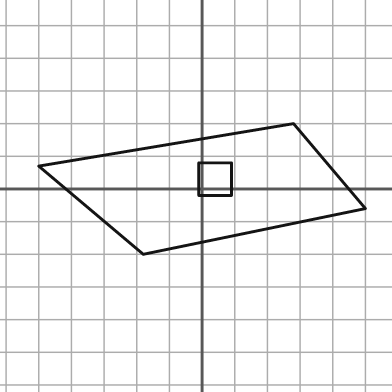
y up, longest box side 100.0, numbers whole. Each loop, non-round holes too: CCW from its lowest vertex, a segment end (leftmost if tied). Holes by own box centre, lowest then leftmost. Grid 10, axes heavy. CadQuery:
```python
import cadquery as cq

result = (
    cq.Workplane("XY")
    .moveTo(-18.0, -20.0)
    .lineTo(50.0, -6.0)
    .lineTo(28.0, 20.0)
    .lineTo(-50.0, 7.0)
    .close()
    .moveTo(-1.0, -2.0)
    .lineTo(9.0, -2.0)
    .lineTo(9.0, 8.0)
    .lineTo(-1.0, 8.0)
    .close()
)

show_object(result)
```